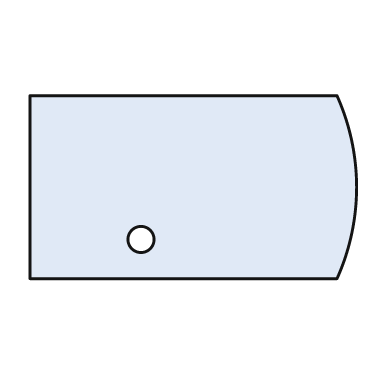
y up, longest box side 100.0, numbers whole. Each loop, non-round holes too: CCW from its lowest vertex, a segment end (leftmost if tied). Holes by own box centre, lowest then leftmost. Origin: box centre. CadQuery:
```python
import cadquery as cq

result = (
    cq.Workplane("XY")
    .moveTo(-50.0, -28.0)
    .lineTo(44.0, -28.0)
    .threePointArc((50.0, 0.0), (44.0, 28.0))
    .lineTo(-50.0, 28.0)
    .close()
    .moveTo(-16.0, -16.0)
    .circle(4.0)
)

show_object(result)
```